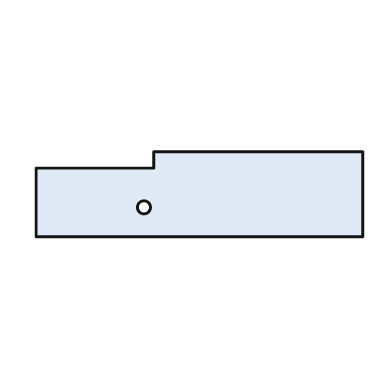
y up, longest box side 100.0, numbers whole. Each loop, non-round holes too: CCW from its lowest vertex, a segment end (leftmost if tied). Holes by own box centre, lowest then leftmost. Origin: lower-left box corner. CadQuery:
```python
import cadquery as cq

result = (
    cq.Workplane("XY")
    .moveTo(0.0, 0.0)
    .lineTo(100.0, 0.0)
    .lineTo(100.0, 26.0)
    .lineTo(36.0, 26.0)
    .lineTo(36.0, 21.0)
    .lineTo(0.0, 21.0)
    .close()
    .moveTo(33.0, 9.0)
    .circle(2.0)
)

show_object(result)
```